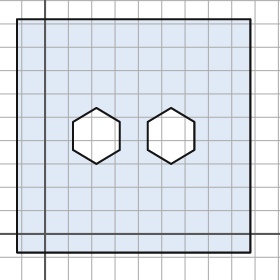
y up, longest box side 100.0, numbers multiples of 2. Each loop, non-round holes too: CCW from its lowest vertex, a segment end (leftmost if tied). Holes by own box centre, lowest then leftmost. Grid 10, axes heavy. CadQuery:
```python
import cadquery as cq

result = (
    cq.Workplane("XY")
    .moveTo(-12.0, -8.0)
    .lineTo(88.0, -8.0)
    .lineTo(88.0, 92.0)
    .lineTo(-12.0, 92.0)
    .close()
    .moveTo(22.0, 30.0)
    .lineTo(32.0, 36.0)
    .lineTo(32.0, 48.0)
    .lineTo(22.0, 54.0)
    .lineTo(12.0, 48.0)
    .lineTo(12.0, 36.0)
    .close()
    .moveTo(54.0, 30.0)
    .lineTo(64.0, 36.0)
    .lineTo(64.0, 48.0)
    .lineTo(54.0, 54.0)
    .lineTo(44.0, 48.0)
    .lineTo(44.0, 36.0)
    .close()
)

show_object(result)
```